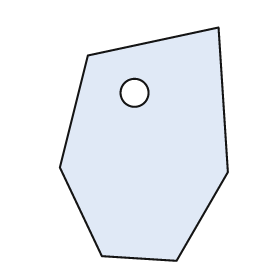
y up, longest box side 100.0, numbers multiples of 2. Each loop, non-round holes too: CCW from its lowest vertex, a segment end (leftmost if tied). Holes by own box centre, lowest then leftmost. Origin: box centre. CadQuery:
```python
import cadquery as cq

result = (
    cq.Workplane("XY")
    .moveTo(14.0, -50.0)
    .lineTo(36.0, -12.0)
    .lineTo(32.0, 50.0)
    .lineTo(-24.0, 38.0)
    .lineTo(-36.0, -10.0)
    .lineTo(-18.0, -48.0)
    .close()
    .moveTo(-4.0, 22.0)
    .circle(6.0)
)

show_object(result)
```